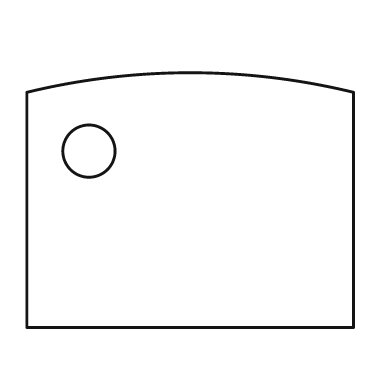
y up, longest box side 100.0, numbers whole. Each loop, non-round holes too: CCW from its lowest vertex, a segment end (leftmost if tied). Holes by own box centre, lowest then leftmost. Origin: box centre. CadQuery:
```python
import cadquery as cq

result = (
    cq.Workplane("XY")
    .moveTo(-50.0, -39.0)
    .lineTo(50.0, -39.0)
    .lineTo(50.0, 33.0)
    .threePointArc((0.0, 39.0), (-50.0, 33.0))
    .close()
    .moveTo(-31.0, 15.0)
    .circle(8.0)
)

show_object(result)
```